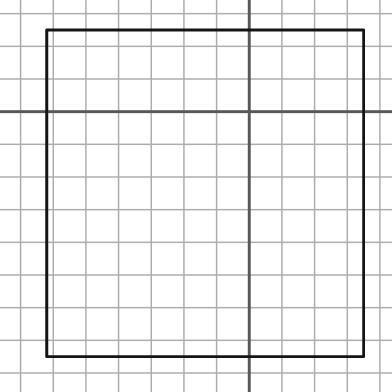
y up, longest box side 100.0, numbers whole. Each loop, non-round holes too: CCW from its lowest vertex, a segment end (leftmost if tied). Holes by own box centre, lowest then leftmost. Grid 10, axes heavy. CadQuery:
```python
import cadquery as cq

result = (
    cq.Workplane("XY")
    .moveTo(-62.0, -75.0)
    .lineTo(35.0, -75.0)
    .lineTo(35.0, 25.0)
    .lineTo(-62.0, 25.0)
    .close()
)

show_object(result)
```